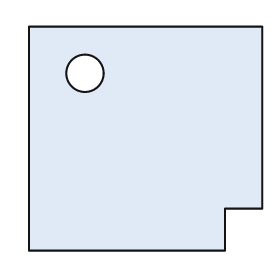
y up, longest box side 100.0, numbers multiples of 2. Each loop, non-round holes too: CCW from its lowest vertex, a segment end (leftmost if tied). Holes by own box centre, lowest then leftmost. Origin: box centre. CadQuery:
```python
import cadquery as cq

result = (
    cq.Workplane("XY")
    .moveTo(-50.0, -48.0)
    .lineTo(34.0, -48.0)
    .lineTo(34.0, -30.0)
    .lineTo(50.0, -30.0)
    .lineTo(50.0, 48.0)
    .lineTo(-50.0, 48.0)
    .close()
    .moveTo(-26.0, 28.0)
    .circle(8.0)
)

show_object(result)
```